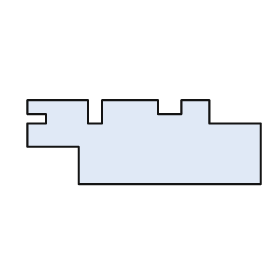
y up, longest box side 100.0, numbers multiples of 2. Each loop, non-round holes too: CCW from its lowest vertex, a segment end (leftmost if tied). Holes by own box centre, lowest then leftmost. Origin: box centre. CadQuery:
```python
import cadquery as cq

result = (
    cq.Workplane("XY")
    .moveTo(-28.0, -18.0)
    .lineTo(50.0, -18.0)
    .lineTo(50.0, 8.0)
    .lineTo(28.0, 8.0)
    .lineTo(28.0, 18.0)
    .lineTo(16.0, 18.0)
    .lineTo(16.0, 12.0)
    .lineTo(6.0, 12.0)
    .lineTo(6.0, 18.0)
    .lineTo(-18.0, 18.0)
    .lineTo(-18.0, 8.0)
    .lineTo(-24.0, 8.0)
    .lineTo(-24.0, 18.0)
    .lineTo(-50.0, 18.0)
    .lineTo(-50.0, 12.0)
    .lineTo(-42.0, 12.0)
    .lineTo(-42.0, 8.0)
    .lineTo(-50.0, 8.0)
    .lineTo(-50.0, -2.0)
    .lineTo(-28.0, -2.0)
    .close()
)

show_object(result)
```